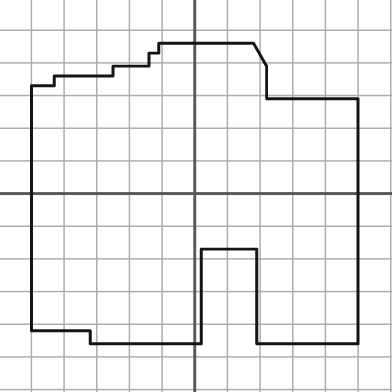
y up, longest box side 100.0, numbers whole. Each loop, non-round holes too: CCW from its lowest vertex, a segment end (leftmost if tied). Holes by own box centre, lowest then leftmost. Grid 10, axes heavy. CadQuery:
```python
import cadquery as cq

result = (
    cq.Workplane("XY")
    .moveTo(-32.0, -46.0)
    .lineTo(2.0, -46.0)
    .lineTo(2.0, -17.0)
    .lineTo(19.0, -17.0)
    .lineTo(19.0, -46.0)
    .lineTo(50.0, -46.0)
    .lineTo(50.0, 29.0)
    .lineTo(22.0, 29.0)
    .lineTo(22.0, 39.0)
    .lineTo(18.0, 46.0)
    .lineTo(-11.0, 46.0)
    .lineTo(-11.0, 43.0)
    .lineTo(-14.0, 43.0)
    .lineTo(-14.0, 39.0)
    .lineTo(-25.0, 39.0)
    .lineTo(-25.0, 36.0)
    .lineTo(-43.0, 36.0)
    .lineTo(-43.0, 33.0)
    .lineTo(-50.0, 33.0)
    .lineTo(-50.0, -42.0)
    .lineTo(-32.0, -42.0)
    .close()
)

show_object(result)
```